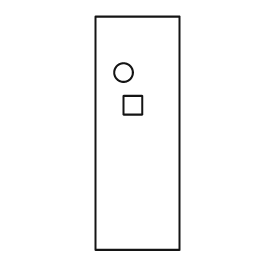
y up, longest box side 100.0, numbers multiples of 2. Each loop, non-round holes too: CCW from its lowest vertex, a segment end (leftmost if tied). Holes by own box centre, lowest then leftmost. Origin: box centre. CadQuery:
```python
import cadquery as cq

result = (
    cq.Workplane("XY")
    .moveTo(-18.0, -50.0)
    .lineTo(18.0, -50.0)
    .lineTo(18.0, 50.0)
    .lineTo(-18.0, 50.0)
    .close()
    .moveTo(-6.0, 8.0)
    .lineTo(2.0, 8.0)
    .lineTo(2.0, 16.0)
    .lineTo(-6.0, 16.0)
    .close()
    .moveTo(-6.0, 26.0)
    .circle(4.0)
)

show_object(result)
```